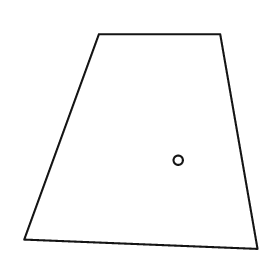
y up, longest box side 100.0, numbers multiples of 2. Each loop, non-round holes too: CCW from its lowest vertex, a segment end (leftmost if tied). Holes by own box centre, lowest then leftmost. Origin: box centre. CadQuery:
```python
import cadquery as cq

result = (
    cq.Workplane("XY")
    .moveTo(50.0, -46.0)
    .lineTo(34.0, 46.0)
    .lineTo(-18.0, 46.0)
    .lineTo(-50.0, -42.0)
    .close()
    .moveTo(16.0, -8.0)
    .circle(2.0)
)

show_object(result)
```